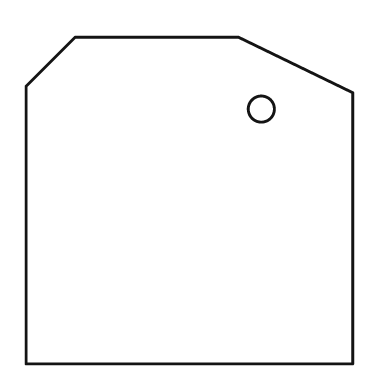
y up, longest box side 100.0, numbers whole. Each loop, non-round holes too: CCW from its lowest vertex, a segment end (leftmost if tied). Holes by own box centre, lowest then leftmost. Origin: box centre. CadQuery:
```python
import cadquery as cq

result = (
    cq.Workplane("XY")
    .moveTo(-50.0, -50.0)
    .lineTo(50.0, -50.0)
    .lineTo(50.0, 33.0)
    .lineTo(15.0, 50.0)
    .lineTo(-35.0, 50.0)
    .lineTo(-50.0, 35.0)
    .close()
    .moveTo(22.0, 28.0)
    .circle(4.0)
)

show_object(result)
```